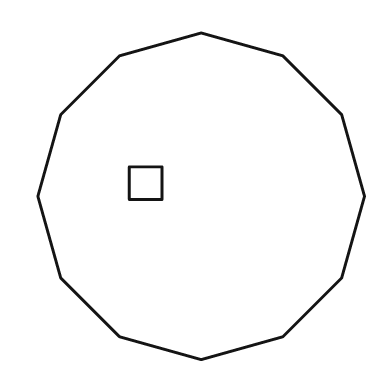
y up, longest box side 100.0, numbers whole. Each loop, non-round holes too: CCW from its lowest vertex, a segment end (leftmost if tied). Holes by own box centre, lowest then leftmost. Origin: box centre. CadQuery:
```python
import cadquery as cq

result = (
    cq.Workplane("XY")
    .moveTo(0.0, -50.0)
    .lineTo(25.0, -43.0)
    .lineTo(43.0, -25.0)
    .lineTo(50.0, 0.0)
    .lineTo(43.0, 25.0)
    .lineTo(25.0, 43.0)
    .lineTo(0.0, 50.0)
    .lineTo(-25.0, 43.0)
    .lineTo(-43.0, 25.0)
    .lineTo(-50.0, 0.0)
    .lineTo(-43.0, -25.0)
    .lineTo(-25.0, -43.0)
    .close()
    .moveTo(-22.0, -1.0)
    .lineTo(-12.0, -1.0)
    .lineTo(-12.0, 9.0)
    .lineTo(-22.0, 9.0)
    .close()
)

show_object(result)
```